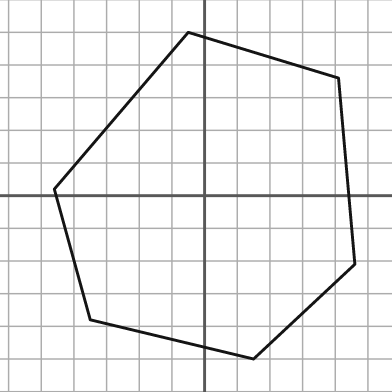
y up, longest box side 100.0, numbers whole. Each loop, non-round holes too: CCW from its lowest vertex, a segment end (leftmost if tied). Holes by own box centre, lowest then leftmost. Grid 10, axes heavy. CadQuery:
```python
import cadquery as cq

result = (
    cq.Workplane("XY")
    .moveTo(15.0, -50.0)
    .lineTo(46.0, -21.0)
    .lineTo(41.0, 36.0)
    .lineTo(-5.0, 50.0)
    .lineTo(-46.0, 2.0)
    .lineTo(-35.0, -38.0)
    .close()
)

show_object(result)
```